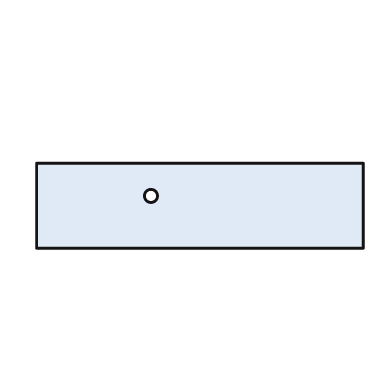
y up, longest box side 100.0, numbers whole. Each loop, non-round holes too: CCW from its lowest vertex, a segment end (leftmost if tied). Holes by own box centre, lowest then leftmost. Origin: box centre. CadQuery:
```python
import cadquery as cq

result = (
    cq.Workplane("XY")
    .moveTo(-50.0, -13.0)
    .lineTo(50.0, -13.0)
    .lineTo(50.0, 13.0)
    .lineTo(-50.0, 13.0)
    .close()
    .moveTo(-15.0, 3.0)
    .circle(2.0)
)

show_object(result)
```